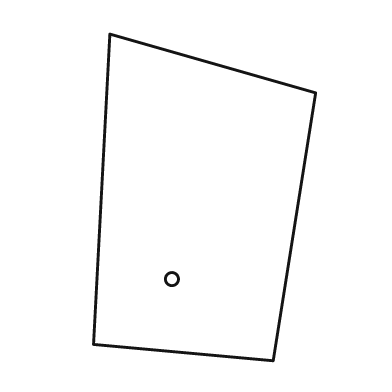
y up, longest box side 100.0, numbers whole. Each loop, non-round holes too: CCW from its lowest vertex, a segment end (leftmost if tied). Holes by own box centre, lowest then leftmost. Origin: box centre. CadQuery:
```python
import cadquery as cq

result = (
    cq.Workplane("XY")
    .moveTo(21.0, -50.0)
    .lineTo(34.0, 32.0)
    .lineTo(-29.0, 50.0)
    .lineTo(-34.0, -45.0)
    .close()
    .moveTo(-10.0, -25.0)
    .circle(2.0)
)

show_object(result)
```